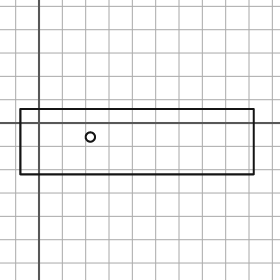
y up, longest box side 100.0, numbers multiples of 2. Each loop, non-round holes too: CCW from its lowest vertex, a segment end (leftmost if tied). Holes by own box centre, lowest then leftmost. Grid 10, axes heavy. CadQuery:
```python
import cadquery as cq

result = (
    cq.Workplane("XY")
    .moveTo(-8.0, -22.0)
    .lineTo(92.0, -22.0)
    .lineTo(92.0, 6.0)
    .lineTo(-8.0, 6.0)
    .close()
    .moveTo(22.0, -6.0)
    .circle(2.0)
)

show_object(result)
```